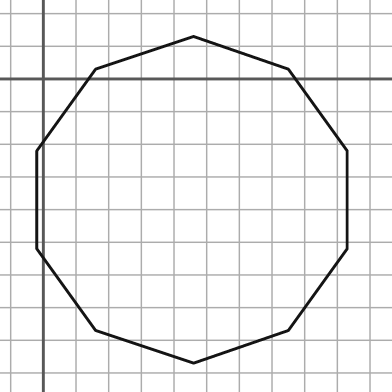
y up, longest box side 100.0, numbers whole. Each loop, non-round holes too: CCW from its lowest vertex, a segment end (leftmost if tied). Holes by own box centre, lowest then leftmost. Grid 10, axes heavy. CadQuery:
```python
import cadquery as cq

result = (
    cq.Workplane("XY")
    .moveTo(46.0, -87.0)
    .lineTo(75.0, -77.0)
    .lineTo(93.0, -52.0)
    .lineTo(93.0, -22.0)
    .lineTo(75.0, 3.0)
    .lineTo(46.0, 13.0)
    .lineTo(16.0, 3.0)
    .lineTo(-2.0, -22.0)
    .lineTo(-2.0, -52.0)
    .lineTo(16.0, -77.0)
    .close()
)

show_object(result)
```